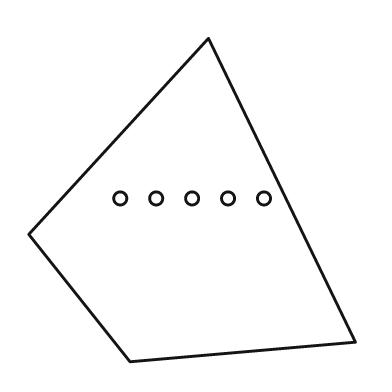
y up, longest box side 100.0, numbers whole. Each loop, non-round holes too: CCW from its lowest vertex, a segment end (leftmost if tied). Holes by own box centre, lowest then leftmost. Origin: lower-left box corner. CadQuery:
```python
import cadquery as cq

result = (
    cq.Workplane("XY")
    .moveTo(31.0, 0.0)
    .lineTo(100.0, 6.0)
    .lineTo(55.0, 99.0)
    .lineTo(0.0, 39.0)
    .close()
    .moveTo(28.0, 50.0)
    .circle(2.0)
    .moveTo(39.0, 50.0)
    .circle(2.0)
    .moveTo(50.0, 50.0)
    .circle(2.0)
    .moveTo(61.0, 50.0)
    .circle(2.0)
    .moveTo(72.0, 50.0)
    .circle(2.0)
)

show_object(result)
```